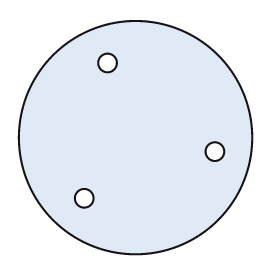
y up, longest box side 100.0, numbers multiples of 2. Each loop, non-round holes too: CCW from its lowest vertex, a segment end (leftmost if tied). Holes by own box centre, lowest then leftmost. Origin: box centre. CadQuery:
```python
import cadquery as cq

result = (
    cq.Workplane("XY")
    .moveTo(0.0, 0.0)
    .circle(50.0)
    .moveTo(-22.0, -26.0)
    .circle(4.0)
    .moveTo(34.0, -6.0)
    .circle(4.0)
    .moveTo(-12.0, 32.0)
    .circle(4.0)
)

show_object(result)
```